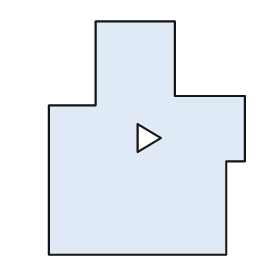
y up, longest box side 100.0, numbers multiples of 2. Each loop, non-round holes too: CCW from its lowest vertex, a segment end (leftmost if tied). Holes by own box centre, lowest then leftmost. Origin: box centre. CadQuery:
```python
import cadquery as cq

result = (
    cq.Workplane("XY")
    .moveTo(-42.0, -50.0)
    .lineTo(34.0, -50.0)
    .lineTo(34.0, -10.0)
    .lineTo(42.0, -10.0)
    .lineTo(42.0, 18.0)
    .lineTo(12.0, 18.0)
    .lineTo(12.0, 50.0)
    .lineTo(-22.0, 50.0)
    .lineTo(-22.0, 14.0)
    .lineTo(-42.0, 14.0)
    .close()
    .moveTo(-4.0, -6.0)
    .lineTo(6.0, 0.0)
    .lineTo(-4.0, 6.0)
    .close()
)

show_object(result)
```